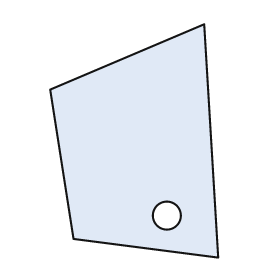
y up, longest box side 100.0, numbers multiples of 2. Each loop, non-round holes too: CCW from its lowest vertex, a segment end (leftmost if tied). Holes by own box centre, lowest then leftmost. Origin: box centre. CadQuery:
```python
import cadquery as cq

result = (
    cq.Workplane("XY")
    .moveTo(36.0, -50.0)
    .lineTo(30.0, 50.0)
    .lineTo(-36.0, 22.0)
    .lineTo(-26.0, -42.0)
    .close()
    .moveTo(14.0, -32.0)
    .circle(6.0)
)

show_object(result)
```